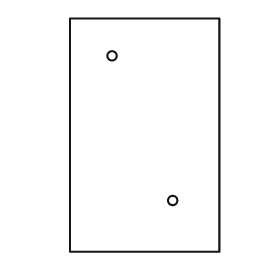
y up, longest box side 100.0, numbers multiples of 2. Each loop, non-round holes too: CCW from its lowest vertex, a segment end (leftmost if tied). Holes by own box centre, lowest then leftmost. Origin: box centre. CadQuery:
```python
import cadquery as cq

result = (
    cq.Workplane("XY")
    .moveTo(-32.0, -50.0)
    .lineTo(32.0, -50.0)
    .lineTo(32.0, 50.0)
    .lineTo(-32.0, 50.0)
    .close()
    .moveTo(12.0, -28.0)
    .circle(2.0)
    .moveTo(-14.0, 34.0)
    .circle(2.0)
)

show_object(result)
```